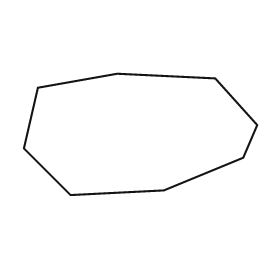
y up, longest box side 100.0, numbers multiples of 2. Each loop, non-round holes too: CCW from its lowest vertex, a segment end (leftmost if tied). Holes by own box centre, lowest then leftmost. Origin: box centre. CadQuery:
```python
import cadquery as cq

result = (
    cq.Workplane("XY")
    .moveTo(-30.0, -26.0)
    .lineTo(10.0, -24.0)
    .lineTo(44.0, -10.0)
    .lineTo(50.0, 4.0)
    .lineTo(32.0, 24.0)
    .lineTo(-10.0, 26.0)
    .lineTo(-44.0, 20.0)
    .lineTo(-50.0, -6.0)
    .close()
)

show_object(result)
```